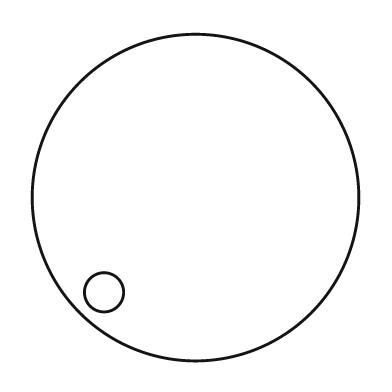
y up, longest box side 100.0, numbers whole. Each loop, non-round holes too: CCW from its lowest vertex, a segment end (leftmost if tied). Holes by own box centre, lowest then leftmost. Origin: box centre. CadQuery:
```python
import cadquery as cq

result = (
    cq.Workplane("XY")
    .moveTo(0.0, 0.0)
    .circle(50.0)
    .moveTo(-28.0, -29.0)
    .circle(6.0)
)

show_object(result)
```